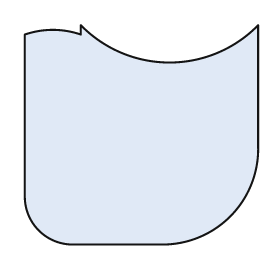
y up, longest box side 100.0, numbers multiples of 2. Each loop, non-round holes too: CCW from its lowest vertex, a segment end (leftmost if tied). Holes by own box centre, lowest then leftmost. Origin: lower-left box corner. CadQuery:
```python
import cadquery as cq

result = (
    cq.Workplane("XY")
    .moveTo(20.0, 0.0)
    .lineTo(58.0, 0.0)
    .threePointArc((88.0, 12.0), (100.0, 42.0))
    .lineTo(100.0, 94.0)
    .threePointArc((62.0, 78.0), (24.0, 94.0))
    .lineTo(24.0, 90.0)
    .threePointArc((12.0, 92.0), (0.0, 90.0))
    .lineTo(0.0, 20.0)
    .threePointArc((6.0, 6.0), (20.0, 0.0))
    .close()
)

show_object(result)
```